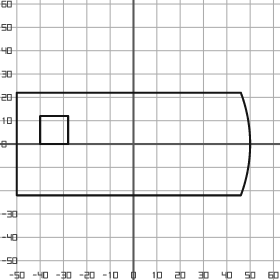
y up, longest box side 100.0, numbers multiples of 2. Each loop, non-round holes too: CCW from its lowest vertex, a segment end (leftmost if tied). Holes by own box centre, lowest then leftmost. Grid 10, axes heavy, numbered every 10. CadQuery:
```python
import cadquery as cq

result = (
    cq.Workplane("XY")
    .moveTo(-50.0, -22.0)
    .lineTo(46.0, -22.0)
    .threePointArc((50.0, 0.0), (46.0, 22.0))
    .lineTo(-50.0, 22.0)
    .close()
    .moveTo(-40.0, 0.0)
    .lineTo(-28.0, 0.0)
    .lineTo(-28.0, 12.0)
    .lineTo(-40.0, 12.0)
    .close()
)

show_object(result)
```